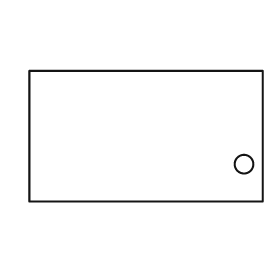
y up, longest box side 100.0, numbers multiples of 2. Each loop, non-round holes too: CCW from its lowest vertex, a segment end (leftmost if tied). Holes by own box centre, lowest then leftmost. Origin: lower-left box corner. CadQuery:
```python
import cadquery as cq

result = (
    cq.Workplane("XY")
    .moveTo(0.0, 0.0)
    .lineTo(100.0, 0.0)
    .lineTo(100.0, 56.0)
    .lineTo(0.0, 56.0)
    .close()
    .moveTo(92.0, 16.0)
    .circle(4.0)
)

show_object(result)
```